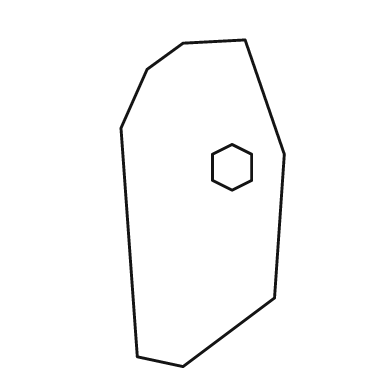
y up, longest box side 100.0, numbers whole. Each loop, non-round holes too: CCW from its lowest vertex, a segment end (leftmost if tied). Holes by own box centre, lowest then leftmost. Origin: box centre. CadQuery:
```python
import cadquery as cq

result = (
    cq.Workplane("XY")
    .moveTo(-6.0, -50.0)
    .lineTo(22.0, -29.0)
    .lineTo(25.0, 15.0)
    .lineTo(13.0, 50.0)
    .lineTo(-6.0, 49.0)
    .lineTo(-17.0, 41.0)
    .lineTo(-25.0, 23.0)
    .lineTo(-20.0, -47.0)
    .close()
    .moveTo(9.0, 4.0)
    .lineTo(15.0, 7.0)
    .lineTo(15.0, 15.0)
    .lineTo(9.0, 18.0)
    .lineTo(3.0, 15.0)
    .lineTo(3.0, 7.0)
    .close()
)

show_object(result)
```